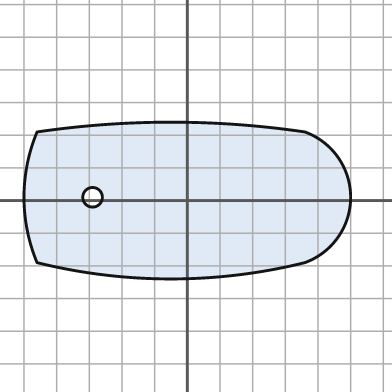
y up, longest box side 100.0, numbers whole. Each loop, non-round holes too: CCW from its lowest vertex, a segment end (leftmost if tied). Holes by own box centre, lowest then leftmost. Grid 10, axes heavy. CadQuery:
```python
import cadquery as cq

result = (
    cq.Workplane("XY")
    .moveTo(-46.0, -19.0)
    .threePointArc((-5.0, -24.0), (36.0, -19.0))
    .threePointArc((50.0, 1.0), (36.0, 21.0))
    .threePointArc((-5.0, 24.0), (-46.0, 21.0))
    .threePointArc((-50.0, 1.0), (-46.0, -19.0))
    .close()
    .moveTo(-29.0, 1.0)
    .circle(3.0)
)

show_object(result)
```